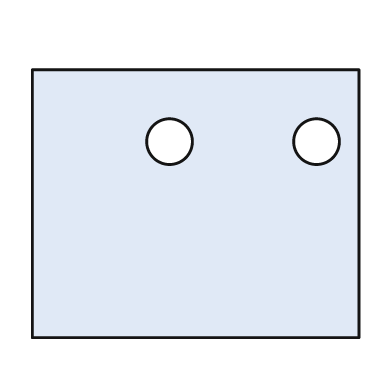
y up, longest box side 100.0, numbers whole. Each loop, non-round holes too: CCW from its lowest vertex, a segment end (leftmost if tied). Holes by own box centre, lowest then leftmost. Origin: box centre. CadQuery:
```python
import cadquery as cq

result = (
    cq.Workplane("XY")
    .moveTo(-50.0, -41.0)
    .lineTo(50.0, -41.0)
    .lineTo(50.0, 41.0)
    .lineTo(-50.0, 41.0)
    .close()
    .moveTo(-8.0, 19.0)
    .circle(7.0)
    .moveTo(37.0, 19.0)
    .circle(7.0)
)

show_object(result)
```